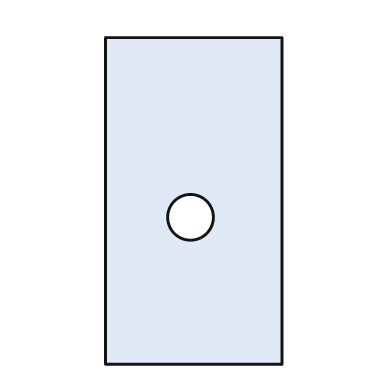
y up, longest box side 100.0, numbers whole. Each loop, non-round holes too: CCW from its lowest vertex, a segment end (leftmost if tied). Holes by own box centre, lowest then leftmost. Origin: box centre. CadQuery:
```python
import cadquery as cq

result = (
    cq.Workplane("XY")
    .moveTo(-27.0, -50.0)
    .lineTo(27.0, -50.0)
    .lineTo(27.0, 50.0)
    .lineTo(-27.0, 50.0)
    .close()
    .moveTo(-1.0, -5.0)
    .circle(7.0)
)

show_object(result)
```